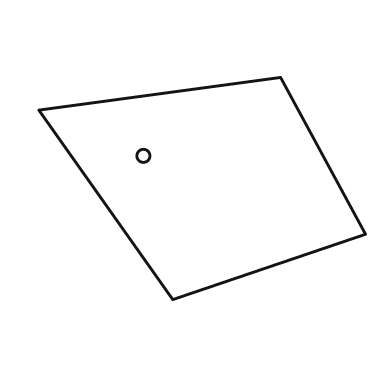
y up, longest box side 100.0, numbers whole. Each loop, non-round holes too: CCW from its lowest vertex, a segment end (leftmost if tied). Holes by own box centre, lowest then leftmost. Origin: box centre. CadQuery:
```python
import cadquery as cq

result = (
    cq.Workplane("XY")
    .moveTo(-9.0, -34.0)
    .lineTo(50.0, -14.0)
    .lineTo(24.0, 34.0)
    .lineTo(-50.0, 24.0)
    .close()
    .moveTo(-18.0, 10.0)
    .circle(2.0)
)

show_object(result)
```